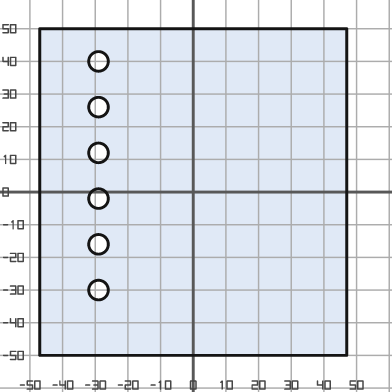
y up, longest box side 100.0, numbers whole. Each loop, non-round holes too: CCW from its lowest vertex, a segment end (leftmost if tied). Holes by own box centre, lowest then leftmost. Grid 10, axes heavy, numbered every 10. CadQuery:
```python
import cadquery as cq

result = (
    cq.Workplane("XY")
    .moveTo(-47.0, -50.0)
    .lineTo(47.0, -50.0)
    .lineTo(47.0, 50.0)
    .lineTo(-47.0, 50.0)
    .close()
    .moveTo(-29.0, -30.0)
    .circle(3.0)
    .moveTo(-29.0, -16.0)
    .circle(3.0)
    .moveTo(-29.0, -2.0)
    .circle(3.0)
    .moveTo(-29.0, 12.0)
    .circle(3.0)
    .moveTo(-29.0, 26.0)
    .circle(3.0)
    .moveTo(-29.0, 40.0)
    .circle(3.0)
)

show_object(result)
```